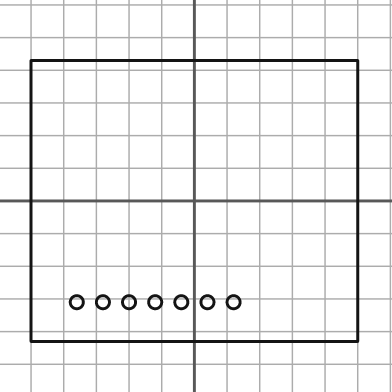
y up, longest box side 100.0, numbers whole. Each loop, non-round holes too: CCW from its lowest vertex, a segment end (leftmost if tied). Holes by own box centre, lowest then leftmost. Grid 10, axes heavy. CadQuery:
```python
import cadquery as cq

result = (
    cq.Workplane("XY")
    .moveTo(-50.0, -43.0)
    .lineTo(50.0, -43.0)
    .lineTo(50.0, 43.0)
    .lineTo(-50.0, 43.0)
    .close()
    .moveTo(-36.0, -31.0)
    .circle(2.0)
    .moveTo(-28.0, -31.0)
    .circle(2.0)
    .moveTo(-20.0, -31.0)
    .circle(2.0)
    .moveTo(-12.0, -31.0)
    .circle(2.0)
    .moveTo(-4.0, -31.0)
    .circle(2.0)
    .moveTo(4.0, -31.0)
    .circle(2.0)
    .moveTo(12.0, -31.0)
    .circle(2.0)
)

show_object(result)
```